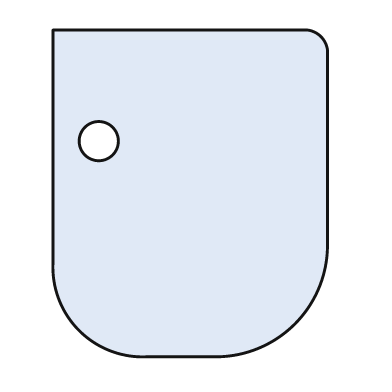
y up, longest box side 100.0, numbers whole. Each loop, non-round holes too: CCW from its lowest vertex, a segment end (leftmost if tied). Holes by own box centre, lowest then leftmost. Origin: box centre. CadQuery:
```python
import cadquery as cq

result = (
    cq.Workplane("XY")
    .moveTo(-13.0, -50.0)
    .lineTo(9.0, -50.0)
    .threePointArc((32.0, -40.0), (42.0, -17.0))
    .lineTo(42.0, 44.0)
    .threePointArc((40.0, 48.0), (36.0, 50.0))
    .lineTo(-42.0, 50.0)
    .lineTo(-42.0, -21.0)
    .threePointArc((-34.0, -42.0), (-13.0, -50.0))
    .close()
    .moveTo(-28.0, 16.0)
    .circle(6.0)
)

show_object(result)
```